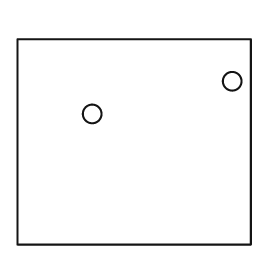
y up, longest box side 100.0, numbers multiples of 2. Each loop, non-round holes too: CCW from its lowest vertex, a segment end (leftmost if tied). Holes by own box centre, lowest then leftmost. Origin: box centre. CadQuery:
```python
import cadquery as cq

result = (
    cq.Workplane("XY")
    .moveTo(-50.0, -44.0)
    .lineTo(50.0, -44.0)
    .lineTo(50.0, 44.0)
    .lineTo(-50.0, 44.0)
    .close()
    .moveTo(-18.0, 12.0)
    .circle(4.0)
    .moveTo(42.0, 26.0)
    .circle(4.0)
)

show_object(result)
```